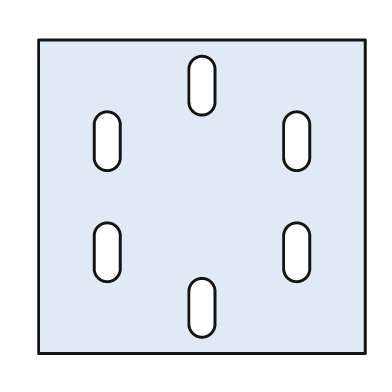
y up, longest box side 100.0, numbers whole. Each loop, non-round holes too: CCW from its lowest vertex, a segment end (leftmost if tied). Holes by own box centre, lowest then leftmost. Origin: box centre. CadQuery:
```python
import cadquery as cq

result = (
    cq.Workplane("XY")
    .moveTo(-50.0, -48.0)
    .lineTo(50.0, -48.0)
    .lineTo(50.0, 48.0)
    .lineTo(-50.0, 48.0)
    .close()
    .moveTo(-4.0, -39.0)
    .threePointArc((0.0, -43.0), (4.0, -39.0))
    .lineTo(4.0, -29.0)
    .threePointArc((0.0, -25.0), (-4.0, -29.0))
    .close()
    .moveTo(-33.0, -22.0)
    .threePointArc((-29.0, -26.0), (-25.0, -22.0))
    .lineTo(-25.0, -12.0)
    .threePointArc((-29.0, -8.0), (-33.0, -12.0))
    .close()
    .moveTo(25.0, -22.0)
    .threePointArc((29.0, -26.0), (33.0, -22.0))
    .lineTo(33.0, -12.0)
    .threePointArc((29.0, -8.0), (25.0, -12.0))
    .close()
    .moveTo(-33.0, 12.0)
    .threePointArc((-29.0, 8.0), (-25.0, 12.0))
    .lineTo(-25.0, 22.0)
    .threePointArc((-29.0, 26.0), (-33.0, 22.0))
    .close()
    .moveTo(25.0, 12.0)
    .threePointArc((29.0, 8.0), (33.0, 12.0))
    .lineTo(33.0, 22.0)
    .threePointArc((29.0, 26.0), (25.0, 22.0))
    .close()
    .moveTo(-4.0, 29.0)
    .threePointArc((0.0, 25.0), (4.0, 29.0))
    .lineTo(4.0, 39.0)
    .threePointArc((0.0, 43.0), (-4.0, 39.0))
    .close()
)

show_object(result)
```